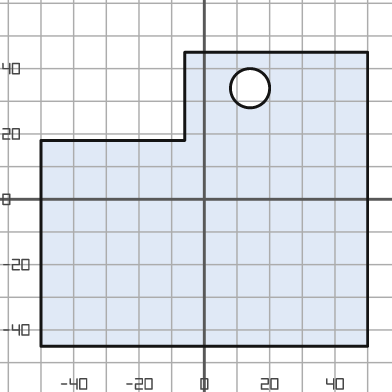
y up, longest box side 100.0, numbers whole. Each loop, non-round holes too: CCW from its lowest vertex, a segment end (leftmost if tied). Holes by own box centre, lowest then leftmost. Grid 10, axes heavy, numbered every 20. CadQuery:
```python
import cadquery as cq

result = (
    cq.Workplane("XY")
    .moveTo(-50.0, -45.0)
    .lineTo(50.0, -45.0)
    .lineTo(50.0, 45.0)
    .lineTo(-6.0, 45.0)
    .lineTo(-6.0, 18.0)
    .lineTo(-50.0, 18.0)
    .close()
    .moveTo(14.0, 34.0)
    .circle(6.0)
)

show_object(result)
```